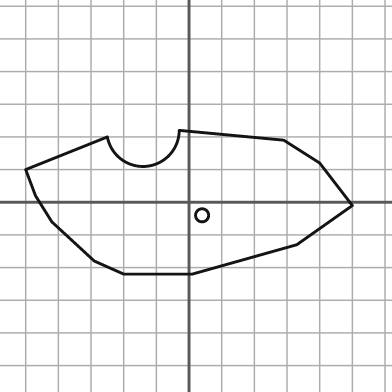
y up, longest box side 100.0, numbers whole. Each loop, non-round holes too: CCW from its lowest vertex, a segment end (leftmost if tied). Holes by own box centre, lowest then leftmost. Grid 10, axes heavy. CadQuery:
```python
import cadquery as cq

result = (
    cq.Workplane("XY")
    .moveTo(-20.0, -22.0)
    .lineTo(1.0, -22.0)
    .lineTo(33.0, -13.0)
    .lineTo(50.0, -1.0)
    .lineTo(40.0, 12.0)
    .lineTo(29.0, 19.0)
    .lineTo(-3.0, 22.0)
    .threePointArc((-13.0, 11.0), (-25.0, 20.0))
    .lineTo(-50.0, 10.0)
    .lineTo(-47.0, 2.0)
    .lineTo(-42.0, -6.0)
    .lineTo(-29.0, -18.0)
    .close()
    .moveTo(4.0, -4.0)
    .circle(2.0)
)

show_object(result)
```